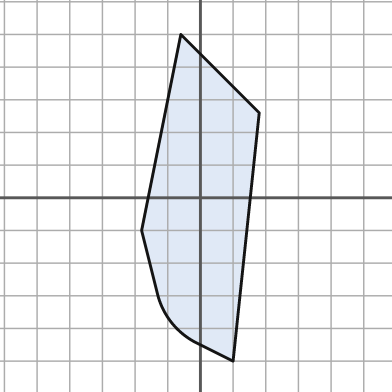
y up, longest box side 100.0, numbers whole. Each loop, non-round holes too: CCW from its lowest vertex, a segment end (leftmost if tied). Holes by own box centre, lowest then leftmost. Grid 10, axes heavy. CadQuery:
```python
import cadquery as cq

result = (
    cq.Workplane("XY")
    .moveTo(10.0, -50.0)
    .lineTo(18.0, 26.0)
    .lineTo(-6.0, 50.0)
    .lineTo(-18.0, -10.0)
    .lineTo(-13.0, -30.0)
    .threePointArc((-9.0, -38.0), (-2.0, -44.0))
    .close()
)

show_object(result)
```